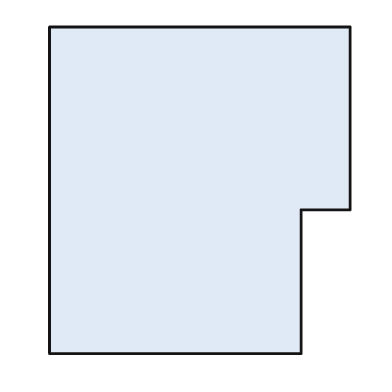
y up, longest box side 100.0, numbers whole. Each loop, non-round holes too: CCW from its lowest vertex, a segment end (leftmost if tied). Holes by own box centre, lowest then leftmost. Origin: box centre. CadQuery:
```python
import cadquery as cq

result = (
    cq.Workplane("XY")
    .moveTo(-46.0, -50.0)
    .lineTo(31.0, -50.0)
    .lineTo(31.0, -6.0)
    .lineTo(46.0, -6.0)
    .lineTo(46.0, 50.0)
    .lineTo(-46.0, 50.0)
    .close()
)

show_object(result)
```